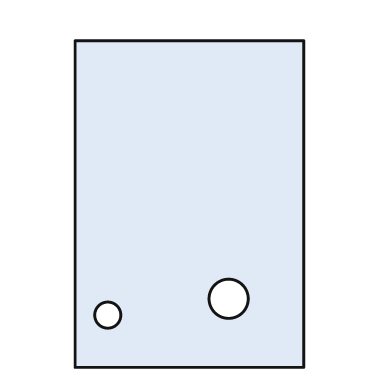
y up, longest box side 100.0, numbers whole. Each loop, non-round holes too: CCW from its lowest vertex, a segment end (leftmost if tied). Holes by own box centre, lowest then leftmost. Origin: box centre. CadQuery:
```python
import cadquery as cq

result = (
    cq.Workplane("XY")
    .moveTo(-35.0, -50.0)
    .lineTo(35.0, -50.0)
    .lineTo(35.0, 50.0)
    .lineTo(-35.0, 50.0)
    .close()
    .moveTo(-25.0, -34.0)
    .circle(4.0)
    .moveTo(12.0, -29.0)
    .circle(6.0)
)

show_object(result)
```